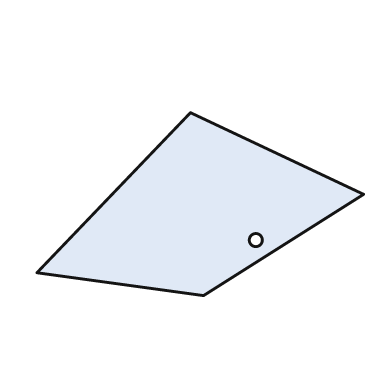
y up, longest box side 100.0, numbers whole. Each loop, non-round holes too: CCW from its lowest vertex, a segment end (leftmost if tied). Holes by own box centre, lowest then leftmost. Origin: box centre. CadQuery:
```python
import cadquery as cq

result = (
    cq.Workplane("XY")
    .moveTo(1.0, -28.0)
    .lineTo(50.0, 3.0)
    .lineTo(-3.0, 28.0)
    .lineTo(-50.0, -21.0)
    .close()
    .moveTo(17.0, -11.0)
    .circle(2.0)
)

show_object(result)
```